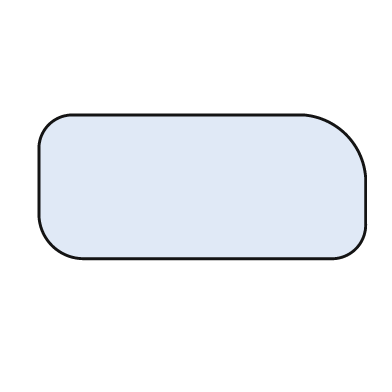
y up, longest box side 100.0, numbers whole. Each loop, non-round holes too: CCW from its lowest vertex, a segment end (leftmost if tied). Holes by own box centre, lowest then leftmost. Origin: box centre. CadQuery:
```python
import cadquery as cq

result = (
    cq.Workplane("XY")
    .moveTo(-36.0, -22.0)
    .lineTo(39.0, -22.0)
    .threePointArc((47.0, -19.0), (50.0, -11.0))
    .lineTo(50.0, 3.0)
    .threePointArc((44.0, 16.0), (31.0, 22.0))
    .lineTo(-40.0, 22.0)
    .threePointArc((-47.0, 19.0), (-50.0, 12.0))
    .lineTo(-50.0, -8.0)
    .threePointArc((-46.0, -18.0), (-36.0, -22.0))
    .close()
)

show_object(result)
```